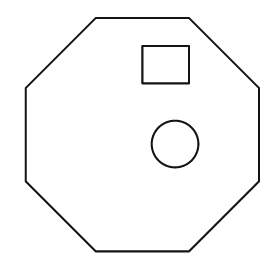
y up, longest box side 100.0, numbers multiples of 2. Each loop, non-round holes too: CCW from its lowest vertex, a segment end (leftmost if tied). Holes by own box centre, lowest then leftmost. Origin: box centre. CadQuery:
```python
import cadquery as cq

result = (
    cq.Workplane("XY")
    .moveTo(-20.0, -50.0)
    .lineTo(20.0, -50.0)
    .lineTo(50.0, -20.0)
    .lineTo(50.0, 20.0)
    .lineTo(20.0, 50.0)
    .lineTo(-20.0, 50.0)
    .lineTo(-50.0, 20.0)
    .lineTo(-50.0, -20.0)
    .close()
    .moveTo(14.0, -4.0)
    .circle(10.0)
    .moveTo(0.0, 22.0)
    .lineTo(20.0, 22.0)
    .lineTo(20.0, 38.0)
    .lineTo(0.0, 38.0)
    .close()
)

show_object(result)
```